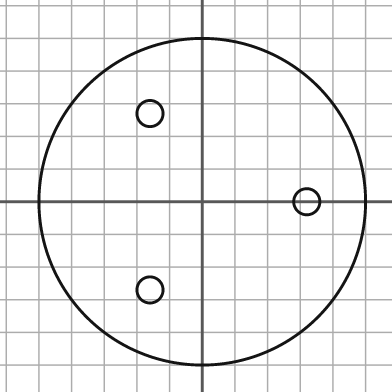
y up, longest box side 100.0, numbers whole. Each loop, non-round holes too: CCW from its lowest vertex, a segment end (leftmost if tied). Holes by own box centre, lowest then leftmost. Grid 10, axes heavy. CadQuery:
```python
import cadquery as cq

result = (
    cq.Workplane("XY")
    .moveTo(0.0, 0.0)
    .circle(50.0)
    .moveTo(-16.0, -27.0)
    .circle(4.0)
    .moveTo(32.0, 0.0)
    .circle(4.0)
    .moveTo(-16.0, 27.0)
    .circle(4.0)
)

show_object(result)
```